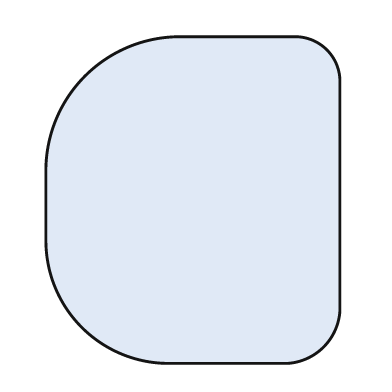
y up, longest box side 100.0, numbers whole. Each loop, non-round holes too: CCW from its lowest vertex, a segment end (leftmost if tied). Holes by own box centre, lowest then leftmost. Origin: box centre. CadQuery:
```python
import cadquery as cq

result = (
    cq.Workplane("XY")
    .moveTo(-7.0, -50.0)
    .lineTo(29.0, -50.0)
    .threePointArc((40.0, -45.0), (45.0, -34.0))
    .lineTo(45.0, 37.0)
    .threePointArc((41.0, 46.0), (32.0, 50.0))
    .lineTo(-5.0, 50.0)
    .threePointArc((-33.0, 38.0), (-45.0, 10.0))
    .lineTo(-45.0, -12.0)
    .threePointArc((-34.0, -39.0), (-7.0, -50.0))
    .close()
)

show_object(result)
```